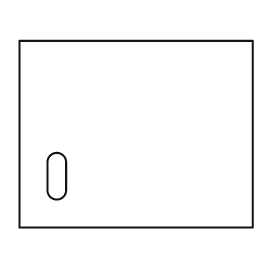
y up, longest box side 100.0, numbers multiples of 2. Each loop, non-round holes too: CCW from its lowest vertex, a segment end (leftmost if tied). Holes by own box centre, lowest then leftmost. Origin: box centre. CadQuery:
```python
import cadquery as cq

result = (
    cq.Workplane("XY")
    .moveTo(-50.0, -40.0)
    .lineTo(50.0, -40.0)
    .lineTo(50.0, 40.0)
    .lineTo(-50.0, 40.0)
    .close()
    .moveTo(-38.0, -24.0)
    .threePointArc((-34.0, -28.0), (-30.0, -24.0))
    .lineTo(-30.0, -12.0)
    .threePointArc((-34.0, -8.0), (-38.0, -12.0))
    .close()
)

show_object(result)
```